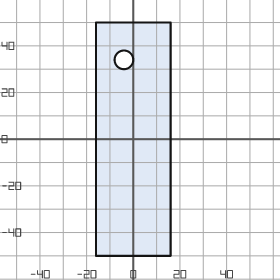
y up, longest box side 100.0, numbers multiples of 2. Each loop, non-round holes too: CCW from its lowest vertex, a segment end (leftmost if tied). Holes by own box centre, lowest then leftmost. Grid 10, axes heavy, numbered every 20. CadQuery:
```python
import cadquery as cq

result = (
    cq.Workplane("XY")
    .moveTo(-16.0, -50.0)
    .lineTo(16.0, -50.0)
    .lineTo(16.0, 50.0)
    .lineTo(-16.0, 50.0)
    .close()
    .moveTo(-4.0, 34.0)
    .circle(4.0)
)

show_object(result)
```